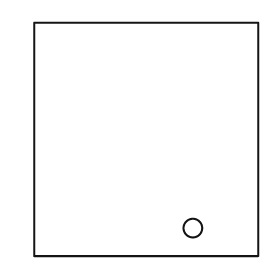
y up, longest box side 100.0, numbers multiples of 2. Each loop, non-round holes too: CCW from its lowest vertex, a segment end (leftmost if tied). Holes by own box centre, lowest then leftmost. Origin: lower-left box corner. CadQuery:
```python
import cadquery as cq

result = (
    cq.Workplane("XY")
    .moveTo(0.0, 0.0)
    .lineTo(96.0, 0.0)
    .lineTo(96.0, 100.0)
    .lineTo(0.0, 100.0)
    .close()
    .moveTo(68.0, 12.0)
    .circle(4.0)
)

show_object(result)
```